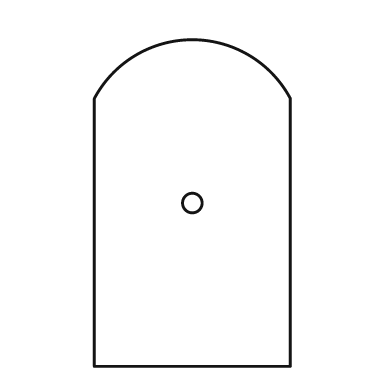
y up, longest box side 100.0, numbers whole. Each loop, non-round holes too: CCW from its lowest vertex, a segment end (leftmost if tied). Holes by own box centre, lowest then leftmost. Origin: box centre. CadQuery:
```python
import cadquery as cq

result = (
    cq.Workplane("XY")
    .moveTo(-30.0, -50.0)
    .lineTo(30.0, -50.0)
    .lineTo(30.0, 32.0)
    .threePointArc((0.0, 50.0), (-30.0, 32.0))
    .close()
    .moveTo(0.0, 0.0)
    .circle(3.0)
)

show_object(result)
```